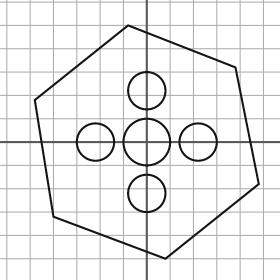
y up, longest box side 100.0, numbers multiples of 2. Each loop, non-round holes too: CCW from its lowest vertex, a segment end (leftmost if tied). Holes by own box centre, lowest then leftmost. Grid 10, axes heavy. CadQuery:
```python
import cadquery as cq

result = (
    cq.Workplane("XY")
    .moveTo(8.0, -50.0)
    .lineTo(48.0, -18.0)
    .lineTo(38.0, 32.0)
    .lineTo(-8.0, 50.0)
    .lineTo(-48.0, 18.0)
    .lineTo(-40.0, -32.0)
    .close()
    .moveTo(0.0, -22.0)
    .circle(8.0)
    .moveTo(-22.0, 0.0)
    .circle(8.0)
    .moveTo(0.0, 0.0)
    .circle(10.0)
    .moveTo(22.0, 0.0)
    .circle(8.0)
    .moveTo(0.0, 22.0)
    .circle(8.0)
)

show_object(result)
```